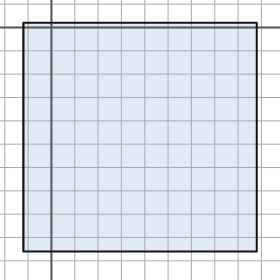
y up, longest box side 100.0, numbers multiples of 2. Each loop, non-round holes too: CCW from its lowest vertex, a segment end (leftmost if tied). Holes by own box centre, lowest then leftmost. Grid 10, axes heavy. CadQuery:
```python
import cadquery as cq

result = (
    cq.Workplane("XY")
    .moveTo(-12.0, -96.0)
    .lineTo(88.0, -96.0)
    .lineTo(88.0, 2.0)
    .lineTo(-12.0, 2.0)
    .close()
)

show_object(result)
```